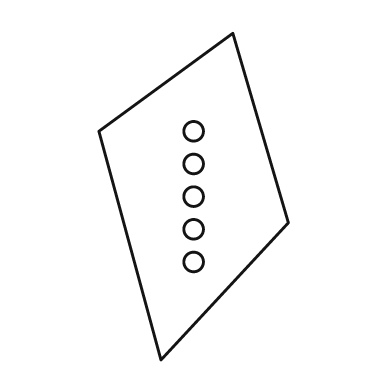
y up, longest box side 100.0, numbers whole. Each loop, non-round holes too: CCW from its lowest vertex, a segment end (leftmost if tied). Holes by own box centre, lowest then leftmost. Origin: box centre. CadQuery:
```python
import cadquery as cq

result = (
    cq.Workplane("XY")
    .moveTo(-10.0, -50.0)
    .lineTo(29.0, -8.0)
    .lineTo(12.0, 50.0)
    .lineTo(-29.0, 20.0)
    .close()
    .moveTo(0.0, -20.0)
    .circle(3.0)
    .moveTo(0.0, -10.0)
    .circle(3.0)
    .moveTo(0.0, 0.0)
    .circle(3.0)
    .moveTo(0.0, 10.0)
    .circle(3.0)
    .moveTo(0.0, 20.0)
    .circle(3.0)
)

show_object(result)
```